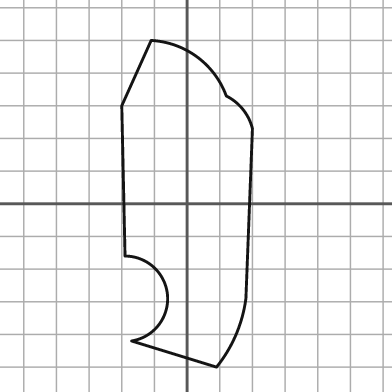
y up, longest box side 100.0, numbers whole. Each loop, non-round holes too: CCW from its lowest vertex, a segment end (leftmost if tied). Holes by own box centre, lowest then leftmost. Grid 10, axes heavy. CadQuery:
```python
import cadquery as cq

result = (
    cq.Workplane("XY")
    .moveTo(9.0, -50.0)
    .threePointArc((15.0, -40.0), (18.0, -29.0))
    .lineTo(20.0, 23.0)
    .threePointArc((17.0, 29.0), (12.0, 33.0))
    .threePointArc((3.0, 45.0), (-11.0, 50.0))
    .lineTo(-20.0, 30.0)
    .lineTo(-19.0, -16.0)
    .threePointArc((-6.0, -28.0), (-17.0, -42.0))
    .close()
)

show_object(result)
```